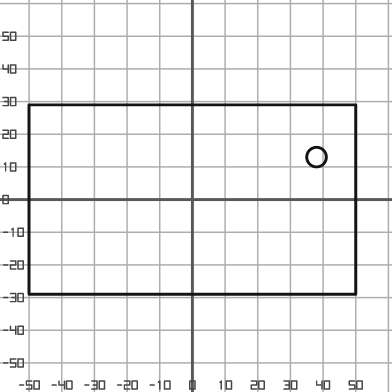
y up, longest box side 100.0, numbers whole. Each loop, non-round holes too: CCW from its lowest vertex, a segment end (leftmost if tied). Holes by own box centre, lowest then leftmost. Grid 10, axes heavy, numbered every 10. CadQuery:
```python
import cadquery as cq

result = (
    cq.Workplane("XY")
    .moveTo(-50.0, -29.0)
    .lineTo(50.0, -29.0)
    .lineTo(50.0, 29.0)
    .lineTo(-50.0, 29.0)
    .close()
    .moveTo(38.0, 13.0)
    .circle(3.0)
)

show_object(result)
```